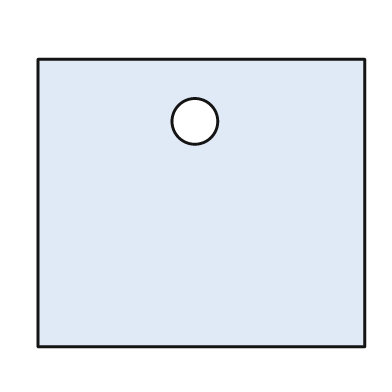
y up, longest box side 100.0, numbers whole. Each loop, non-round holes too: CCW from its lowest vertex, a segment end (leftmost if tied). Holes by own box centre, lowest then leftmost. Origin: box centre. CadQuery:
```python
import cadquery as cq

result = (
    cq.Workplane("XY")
    .moveTo(-50.0, -44.0)
    .lineTo(50.0, -44.0)
    .lineTo(50.0, 44.0)
    .lineTo(-50.0, 44.0)
    .close()
    .moveTo(-2.0, 25.0)
    .circle(7.0)
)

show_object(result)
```